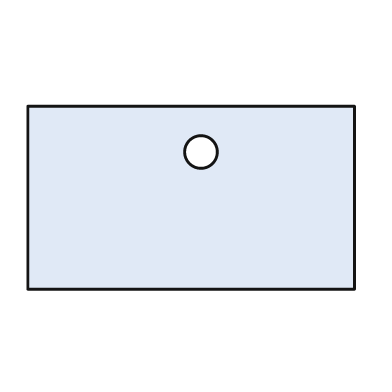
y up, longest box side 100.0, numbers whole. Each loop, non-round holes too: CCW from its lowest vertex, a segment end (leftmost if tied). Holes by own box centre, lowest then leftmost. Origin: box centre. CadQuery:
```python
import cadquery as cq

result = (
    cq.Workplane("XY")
    .moveTo(-50.0, -28.0)
    .lineTo(50.0, -28.0)
    .lineTo(50.0, 28.0)
    .lineTo(-50.0, 28.0)
    .close()
    .moveTo(3.0, 14.0)
    .circle(5.0)
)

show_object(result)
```